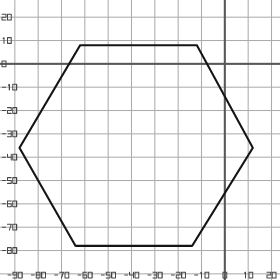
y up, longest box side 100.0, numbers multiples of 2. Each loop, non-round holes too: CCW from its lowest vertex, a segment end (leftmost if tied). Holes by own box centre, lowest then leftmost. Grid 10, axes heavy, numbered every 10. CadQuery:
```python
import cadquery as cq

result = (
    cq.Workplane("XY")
    .moveTo(-64.0, -78.0)
    .lineTo(-14.0, -78.0)
    .lineTo(12.0, -36.0)
    .lineTo(-12.0, 8.0)
    .lineTo(-62.0, 8.0)
    .lineTo(-88.0, -36.0)
    .close()
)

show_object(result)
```